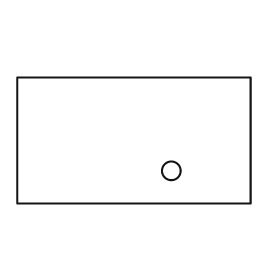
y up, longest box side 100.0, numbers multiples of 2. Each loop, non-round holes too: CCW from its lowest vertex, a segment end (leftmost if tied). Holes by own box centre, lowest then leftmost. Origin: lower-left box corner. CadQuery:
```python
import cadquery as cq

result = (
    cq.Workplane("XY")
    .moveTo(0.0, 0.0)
    .lineTo(100.0, 0.0)
    .lineTo(100.0, 54.0)
    .lineTo(0.0, 54.0)
    .close()
    .moveTo(66.0, 14.0)
    .circle(4.0)
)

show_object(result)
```